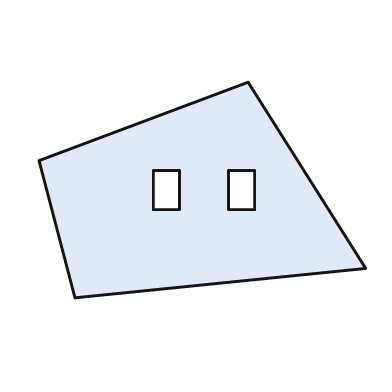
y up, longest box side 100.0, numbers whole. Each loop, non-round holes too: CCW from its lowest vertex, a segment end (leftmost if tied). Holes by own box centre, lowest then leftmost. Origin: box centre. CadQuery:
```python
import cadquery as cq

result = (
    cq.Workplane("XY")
    .moveTo(-39.0, -33.0)
    .lineTo(50.0, -24.0)
    .lineTo(14.0, 33.0)
    .lineTo(-50.0, 9.0)
    .close()
    .moveTo(-15.0, -6.0)
    .lineTo(-7.0, -6.0)
    .lineTo(-7.0, 6.0)
    .lineTo(-15.0, 6.0)
    .close()
    .moveTo(8.0, -6.0)
    .lineTo(16.0, -6.0)
    .lineTo(16.0, 6.0)
    .lineTo(8.0, 6.0)
    .close()
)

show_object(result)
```